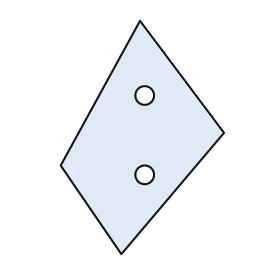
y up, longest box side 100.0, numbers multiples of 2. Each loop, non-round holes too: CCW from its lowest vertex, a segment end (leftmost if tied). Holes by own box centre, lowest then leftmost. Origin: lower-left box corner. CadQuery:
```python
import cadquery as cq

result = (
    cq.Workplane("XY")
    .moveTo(26.0, 0.0)
    .lineTo(70.0, 52.0)
    .lineTo(34.0, 100.0)
    .lineTo(0.0, 38.0)
    .close()
    .moveTo(36.0, 34.0)
    .circle(4.0)
    .moveTo(36.0, 68.0)
    .circle(4.0)
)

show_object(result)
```